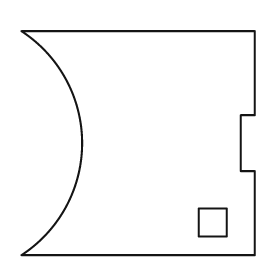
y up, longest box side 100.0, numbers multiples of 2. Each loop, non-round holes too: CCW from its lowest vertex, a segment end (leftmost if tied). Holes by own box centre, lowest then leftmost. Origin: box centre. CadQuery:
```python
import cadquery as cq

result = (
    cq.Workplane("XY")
    .moveTo(-50.0, -48.0)
    .lineTo(50.0, -48.0)
    .lineTo(50.0, -12.0)
    .lineTo(44.0, -12.0)
    .lineTo(44.0, 12.0)
    .lineTo(50.0, 12.0)
    .lineTo(50.0, 48.0)
    .lineTo(-50.0, 48.0)
    .threePointArc((-24.0, 0.0), (-50.0, -48.0))
    .close()
    .moveTo(26.0, -40.0)
    .lineTo(38.0, -40.0)
    .lineTo(38.0, -28.0)
    .lineTo(26.0, -28.0)
    .close()
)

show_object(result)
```